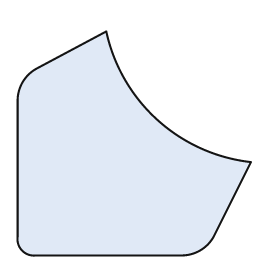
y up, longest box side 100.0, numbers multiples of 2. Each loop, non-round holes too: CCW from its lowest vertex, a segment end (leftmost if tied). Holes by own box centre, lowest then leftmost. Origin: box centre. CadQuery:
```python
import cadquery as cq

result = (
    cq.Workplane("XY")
    .moveTo(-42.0, -48.0)
    .lineTo(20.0, -48.0)
    .threePointArc((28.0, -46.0), (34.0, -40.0))
    .lineTo(50.0, -8.0)
    .threePointArc((10.0, 10.0), (-12.0, 48.0))
    .lineTo(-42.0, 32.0)
    .threePointArc((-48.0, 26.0), (-50.0, 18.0))
    .lineTo(-50.0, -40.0)
    .threePointArc((-48.0, -46.0), (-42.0, -48.0))
    .close()
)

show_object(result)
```